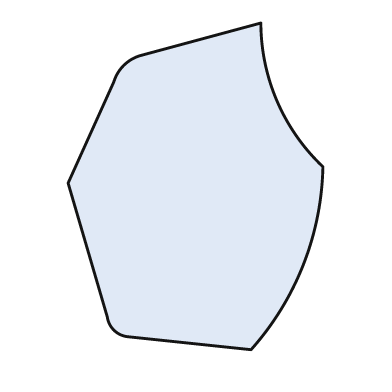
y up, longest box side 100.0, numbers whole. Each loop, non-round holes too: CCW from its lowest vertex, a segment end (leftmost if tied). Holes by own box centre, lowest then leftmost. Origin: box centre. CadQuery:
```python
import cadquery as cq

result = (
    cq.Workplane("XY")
    .moveTo(17.0, -50.0)
    .threePointArc((33.0, -24.0), (39.0, 6.0))
    .threePointArc((25.0, 26.0), (20.0, 50.0))
    .lineTo(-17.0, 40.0)
    .threePointArc((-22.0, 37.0), (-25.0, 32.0))
    .lineTo(-39.0, 1.0)
    .lineTo(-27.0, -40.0)
    .threePointArc((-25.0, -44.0), (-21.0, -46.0))
    .close()
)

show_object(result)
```